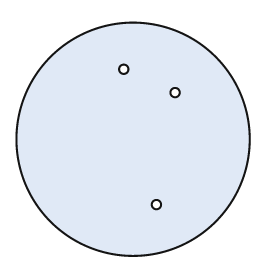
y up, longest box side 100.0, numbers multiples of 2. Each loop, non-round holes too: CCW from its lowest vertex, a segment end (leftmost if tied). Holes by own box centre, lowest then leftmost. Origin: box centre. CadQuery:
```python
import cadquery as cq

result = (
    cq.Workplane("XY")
    .moveTo(0.0, 0.0)
    .circle(50.0)
    .moveTo(10.0, -28.0)
    .circle(2.0)
    .moveTo(18.0, 20.0)
    .circle(2.0)
    .moveTo(-4.0, 30.0)
    .circle(2.0)
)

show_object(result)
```